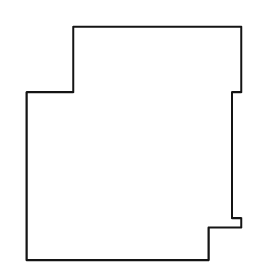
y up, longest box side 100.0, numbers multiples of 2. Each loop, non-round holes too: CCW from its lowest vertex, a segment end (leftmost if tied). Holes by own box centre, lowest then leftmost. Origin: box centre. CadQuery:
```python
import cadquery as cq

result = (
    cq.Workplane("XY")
    .moveTo(-46.0, -50.0)
    .lineTo(32.0, -50.0)
    .lineTo(32.0, -36.0)
    .lineTo(46.0, -36.0)
    .lineTo(46.0, -32.0)
    .lineTo(42.0, -32.0)
    .lineTo(42.0, 22.0)
    .lineTo(46.0, 22.0)
    .lineTo(46.0, 50.0)
    .lineTo(-26.0, 50.0)
    .lineTo(-26.0, 22.0)
    .lineTo(-46.0, 22.0)
    .close()
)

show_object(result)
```